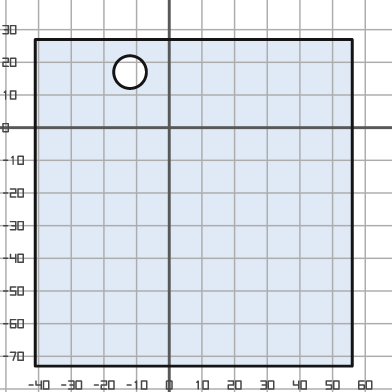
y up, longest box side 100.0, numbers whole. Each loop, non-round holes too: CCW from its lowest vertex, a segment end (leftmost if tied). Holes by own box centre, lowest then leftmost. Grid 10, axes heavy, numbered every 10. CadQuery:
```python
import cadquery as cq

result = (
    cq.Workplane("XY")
    .moveTo(-41.0, -73.0)
    .lineTo(56.0, -73.0)
    .lineTo(56.0, 27.0)
    .lineTo(-41.0, 27.0)
    .close()
    .moveTo(-12.0, 17.0)
    .circle(5.0)
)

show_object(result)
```